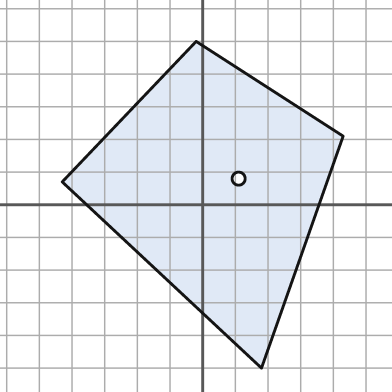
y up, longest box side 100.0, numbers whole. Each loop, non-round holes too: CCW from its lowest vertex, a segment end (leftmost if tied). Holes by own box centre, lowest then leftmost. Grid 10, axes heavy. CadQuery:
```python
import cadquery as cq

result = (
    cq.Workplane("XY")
    .moveTo(18.0, -50.0)
    .lineTo(43.0, 21.0)
    .lineTo(-2.0, 50.0)
    .lineTo(-43.0, 7.0)
    .close()
    .moveTo(11.0, 8.0)
    .circle(2.0)
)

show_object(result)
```